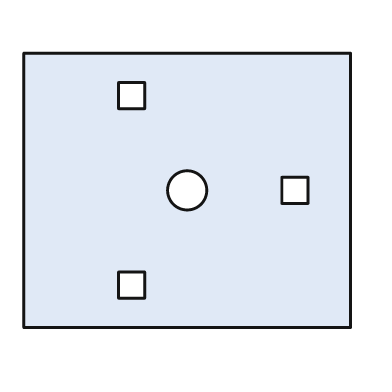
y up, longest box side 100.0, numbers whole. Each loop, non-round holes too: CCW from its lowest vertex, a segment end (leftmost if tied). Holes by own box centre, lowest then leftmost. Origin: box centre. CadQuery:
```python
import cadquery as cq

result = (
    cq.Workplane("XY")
    .moveTo(-50.0, -42.0)
    .lineTo(50.0, -42.0)
    .lineTo(50.0, 42.0)
    .lineTo(-50.0, 42.0)
    .close()
    .moveTo(-21.0, -33.0)
    .lineTo(-13.0, -33.0)
    .lineTo(-13.0, -25.0)
    .lineTo(-21.0, -25.0)
    .close()
    .moveTo(0.0, 0.0)
    .circle(6.0)
    .moveTo(29.0, -4.0)
    .lineTo(37.0, -4.0)
    .lineTo(37.0, 4.0)
    .lineTo(29.0, 4.0)
    .close()
    .moveTo(-21.0, 25.0)
    .lineTo(-13.0, 25.0)
    .lineTo(-13.0, 33.0)
    .lineTo(-21.0, 33.0)
    .close()
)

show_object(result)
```